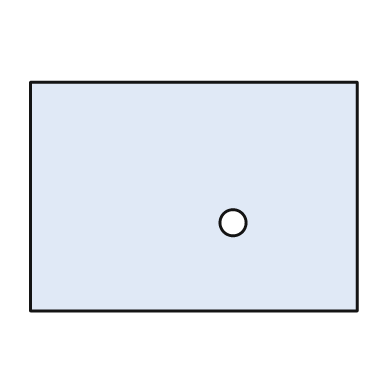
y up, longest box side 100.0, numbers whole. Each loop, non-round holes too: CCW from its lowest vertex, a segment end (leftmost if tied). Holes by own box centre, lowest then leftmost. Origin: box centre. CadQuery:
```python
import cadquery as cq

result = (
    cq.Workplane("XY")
    .moveTo(-50.0, -35.0)
    .lineTo(50.0, -35.0)
    .lineTo(50.0, 35.0)
    .lineTo(-50.0, 35.0)
    .close()
    .moveTo(12.0, -8.0)
    .circle(4.0)
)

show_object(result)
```